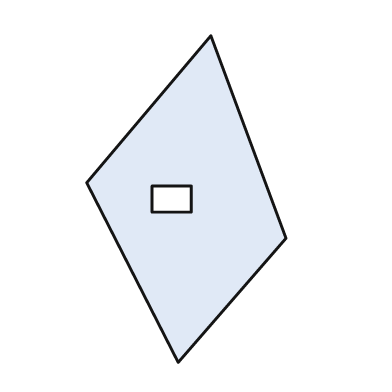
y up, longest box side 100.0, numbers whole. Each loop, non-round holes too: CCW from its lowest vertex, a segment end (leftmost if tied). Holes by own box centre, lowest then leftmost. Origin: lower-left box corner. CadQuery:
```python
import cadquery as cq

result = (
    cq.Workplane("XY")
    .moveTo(28.0, 0.0)
    .lineTo(61.0, 38.0)
    .lineTo(38.0, 100.0)
    .lineTo(0.0, 55.0)
    .close()
    .moveTo(20.0, 46.0)
    .lineTo(32.0, 46.0)
    .lineTo(32.0, 54.0)
    .lineTo(20.0, 54.0)
    .close()
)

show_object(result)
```